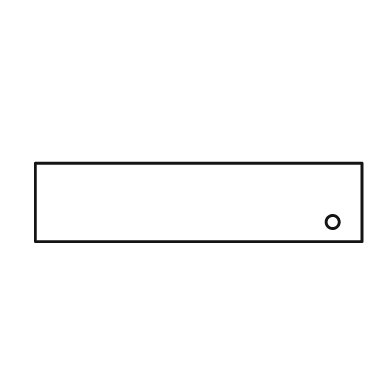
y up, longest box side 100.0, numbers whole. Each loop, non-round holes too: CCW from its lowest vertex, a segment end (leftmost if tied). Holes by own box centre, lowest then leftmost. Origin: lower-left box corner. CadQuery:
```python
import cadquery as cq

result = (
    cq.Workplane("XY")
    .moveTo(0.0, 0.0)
    .lineTo(100.0, 0.0)
    .lineTo(100.0, 24.0)
    .lineTo(0.0, 24.0)
    .close()
    .moveTo(91.0, 6.0)
    .circle(2.0)
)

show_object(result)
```